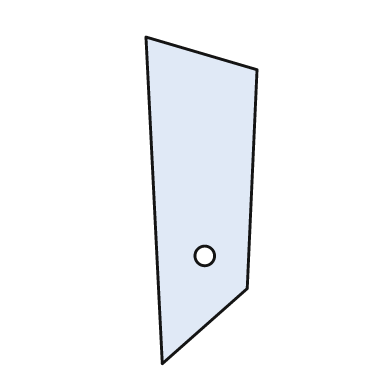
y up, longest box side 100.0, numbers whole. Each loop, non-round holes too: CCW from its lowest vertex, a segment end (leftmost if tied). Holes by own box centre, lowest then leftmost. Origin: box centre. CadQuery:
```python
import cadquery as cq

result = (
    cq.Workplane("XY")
    .moveTo(-12.0, -50.0)
    .lineTo(14.0, -27.0)
    .lineTo(17.0, 40.0)
    .lineTo(-17.0, 50.0)
    .close()
    .moveTo(1.0, -17.0)
    .circle(3.0)
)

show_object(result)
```